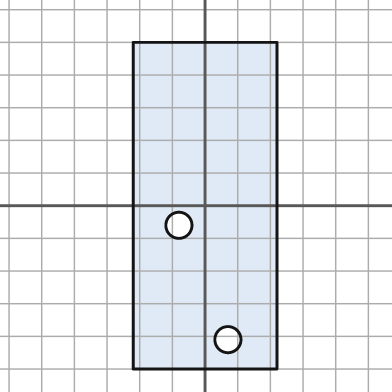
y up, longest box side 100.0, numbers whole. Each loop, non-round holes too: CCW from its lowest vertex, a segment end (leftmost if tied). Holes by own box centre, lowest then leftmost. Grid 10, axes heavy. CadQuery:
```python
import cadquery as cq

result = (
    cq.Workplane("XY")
    .moveTo(-22.0, -50.0)
    .lineTo(22.0, -50.0)
    .lineTo(22.0, 50.0)
    .lineTo(-22.0, 50.0)
    .close()
    .moveTo(7.0, -41.0)
    .circle(4.0)
    .moveTo(-8.0, -6.0)
    .circle(4.0)
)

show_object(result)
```